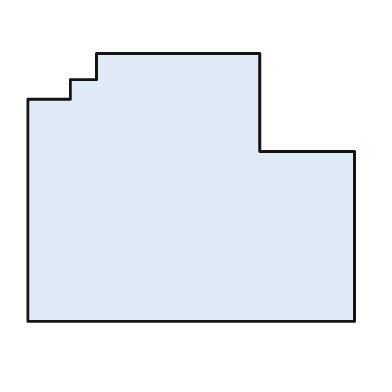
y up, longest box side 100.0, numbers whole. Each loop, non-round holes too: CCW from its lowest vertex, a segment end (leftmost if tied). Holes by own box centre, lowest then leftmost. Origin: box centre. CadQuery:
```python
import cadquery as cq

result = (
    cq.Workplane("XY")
    .moveTo(-50.0, -41.0)
    .lineTo(50.0, -41.0)
    .lineTo(50.0, 11.0)
    .lineTo(21.0, 11.0)
    .lineTo(21.0, 41.0)
    .lineTo(-29.0, 41.0)
    .lineTo(-29.0, 33.0)
    .lineTo(-37.0, 33.0)
    .lineTo(-37.0, 27.0)
    .lineTo(-50.0, 27.0)
    .close()
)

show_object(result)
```